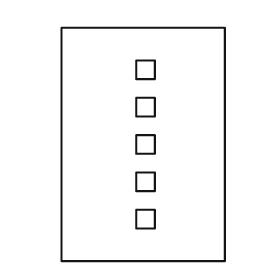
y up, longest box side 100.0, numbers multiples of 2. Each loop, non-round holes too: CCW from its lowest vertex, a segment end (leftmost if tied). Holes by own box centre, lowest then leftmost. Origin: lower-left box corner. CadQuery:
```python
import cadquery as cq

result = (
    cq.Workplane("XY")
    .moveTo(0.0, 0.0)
    .lineTo(70.0, 0.0)
    .lineTo(70.0, 100.0)
    .lineTo(0.0, 100.0)
    .close()
    .moveTo(32.0, 14.0)
    .lineTo(40.0, 14.0)
    .lineTo(40.0, 22.0)
    .lineTo(32.0, 22.0)
    .close()
    .moveTo(32.0, 30.0)
    .lineTo(40.0, 30.0)
    .lineTo(40.0, 38.0)
    .lineTo(32.0, 38.0)
    .close()
    .moveTo(32.0, 46.0)
    .lineTo(40.0, 46.0)
    .lineTo(40.0, 54.0)
    .lineTo(32.0, 54.0)
    .close()
    .moveTo(32.0, 62.0)
    .lineTo(40.0, 62.0)
    .lineTo(40.0, 70.0)
    .lineTo(32.0, 70.0)
    .close()
    .moveTo(32.0, 78.0)
    .lineTo(40.0, 78.0)
    .lineTo(40.0, 86.0)
    .lineTo(32.0, 86.0)
    .close()
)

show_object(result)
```